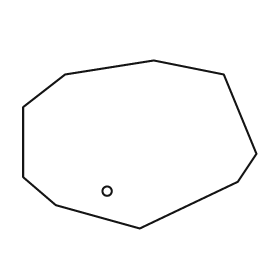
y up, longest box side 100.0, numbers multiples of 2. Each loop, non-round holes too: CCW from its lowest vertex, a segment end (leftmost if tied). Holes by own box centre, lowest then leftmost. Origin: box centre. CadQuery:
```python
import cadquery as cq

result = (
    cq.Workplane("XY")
    .moveTo(0.0, -36.0)
    .lineTo(42.0, -16.0)
    .lineTo(50.0, -4.0)
    .lineTo(36.0, 30.0)
    .lineTo(6.0, 36.0)
    .lineTo(-32.0, 30.0)
    .lineTo(-50.0, 16.0)
    .lineTo(-50.0, -14.0)
    .lineTo(-36.0, -26.0)
    .close()
    .moveTo(-14.0, -20.0)
    .circle(2.0)
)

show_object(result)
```